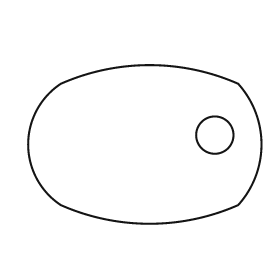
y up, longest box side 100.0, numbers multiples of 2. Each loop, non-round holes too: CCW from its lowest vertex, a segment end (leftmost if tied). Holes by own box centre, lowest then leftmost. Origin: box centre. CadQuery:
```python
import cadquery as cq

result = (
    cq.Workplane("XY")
    .moveTo(-36.0, -26.0)
    .threePointArc((2.0, -34.0), (40.0, -26.0))
    .threePointArc((50.0, 0.0), (40.0, 26.0))
    .threePointArc((2.0, 34.0), (-36.0, 26.0))
    .threePointArc((-50.0, 0.0), (-36.0, -26.0))
    .close()
    .moveTo(30.0, 4.0)
    .circle(8.0)
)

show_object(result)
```